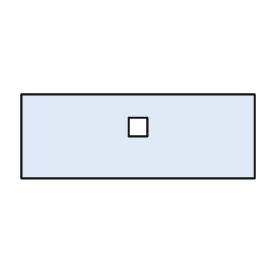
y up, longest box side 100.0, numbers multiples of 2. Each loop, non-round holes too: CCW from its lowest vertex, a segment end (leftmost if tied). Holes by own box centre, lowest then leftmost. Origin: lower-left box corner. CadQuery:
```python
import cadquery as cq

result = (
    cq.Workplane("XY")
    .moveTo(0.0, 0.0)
    .lineTo(100.0, 0.0)
    .lineTo(100.0, 36.0)
    .lineTo(0.0, 36.0)
    .close()
    .moveTo(46.0, 18.0)
    .lineTo(54.0, 18.0)
    .lineTo(54.0, 26.0)
    .lineTo(46.0, 26.0)
    .close()
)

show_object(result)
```